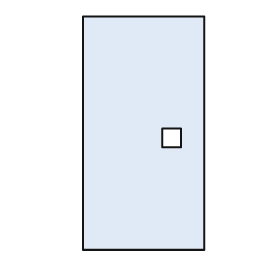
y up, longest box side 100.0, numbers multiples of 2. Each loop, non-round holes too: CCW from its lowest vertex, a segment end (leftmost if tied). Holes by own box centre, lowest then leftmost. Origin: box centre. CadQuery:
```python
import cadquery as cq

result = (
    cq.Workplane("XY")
    .moveTo(-26.0, -50.0)
    .lineTo(26.0, -50.0)
    .lineTo(26.0, 50.0)
    .lineTo(-26.0, 50.0)
    .close()
    .moveTo(8.0, -6.0)
    .lineTo(16.0, -6.0)
    .lineTo(16.0, 2.0)
    .lineTo(8.0, 2.0)
    .close()
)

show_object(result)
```